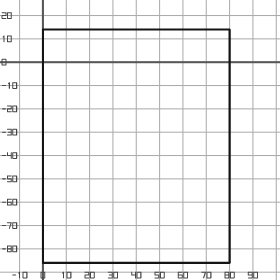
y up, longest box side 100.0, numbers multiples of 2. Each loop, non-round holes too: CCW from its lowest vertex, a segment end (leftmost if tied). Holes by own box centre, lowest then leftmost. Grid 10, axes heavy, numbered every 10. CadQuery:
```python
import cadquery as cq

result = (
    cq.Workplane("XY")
    .moveTo(0.0, -86.0)
    .lineTo(80.0, -86.0)
    .lineTo(80.0, 14.0)
    .lineTo(0.0, 14.0)
    .close()
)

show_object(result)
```